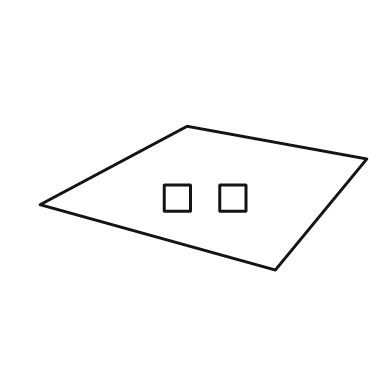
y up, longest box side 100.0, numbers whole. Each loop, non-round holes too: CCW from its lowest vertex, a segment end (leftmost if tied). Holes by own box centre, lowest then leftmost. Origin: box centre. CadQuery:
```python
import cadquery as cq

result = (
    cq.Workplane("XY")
    .moveTo(22.0, -22.0)
    .lineTo(50.0, 12.0)
    .lineTo(-5.0, 22.0)
    .lineTo(-50.0, -2.0)
    .close()
    .moveTo(-12.0, -4.0)
    .lineTo(-4.0, -4.0)
    .lineTo(-4.0, 4.0)
    .lineTo(-12.0, 4.0)
    .close()
    .moveTo(5.0, -4.0)
    .lineTo(13.0, -4.0)
    .lineTo(13.0, 4.0)
    .lineTo(5.0, 4.0)
    .close()
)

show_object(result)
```